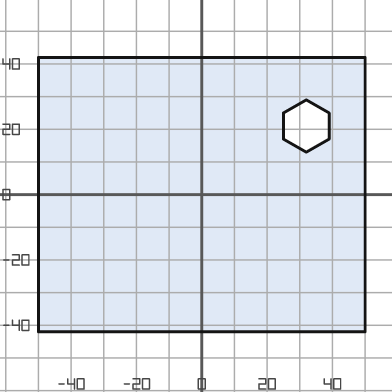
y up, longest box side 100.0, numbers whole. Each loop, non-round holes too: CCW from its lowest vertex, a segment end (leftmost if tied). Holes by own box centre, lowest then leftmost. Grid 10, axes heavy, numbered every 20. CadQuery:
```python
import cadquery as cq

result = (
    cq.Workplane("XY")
    .moveTo(-50.0, -42.0)
    .lineTo(50.0, -42.0)
    .lineTo(50.0, 42.0)
    .lineTo(-50.0, 42.0)
    .close()
    .moveTo(32.0, 13.0)
    .lineTo(39.0, 17.0)
    .lineTo(39.0, 25.0)
    .lineTo(32.0, 29.0)
    .lineTo(25.0, 25.0)
    .lineTo(25.0, 17.0)
    .close()
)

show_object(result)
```